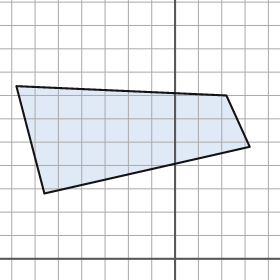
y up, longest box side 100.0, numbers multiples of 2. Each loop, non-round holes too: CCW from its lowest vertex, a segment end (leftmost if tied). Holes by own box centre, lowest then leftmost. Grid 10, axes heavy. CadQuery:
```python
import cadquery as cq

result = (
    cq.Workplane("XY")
    .moveTo(-56.0, 28.0)
    .lineTo(32.0, 48.0)
    .lineTo(22.0, 70.0)
    .lineTo(-68.0, 74.0)
    .close()
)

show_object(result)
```